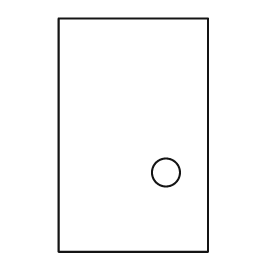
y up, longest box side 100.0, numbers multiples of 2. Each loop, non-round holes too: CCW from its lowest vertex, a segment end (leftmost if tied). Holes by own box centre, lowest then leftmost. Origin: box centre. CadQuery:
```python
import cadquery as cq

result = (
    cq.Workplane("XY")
    .moveTo(-32.0, -50.0)
    .lineTo(32.0, -50.0)
    .lineTo(32.0, 50.0)
    .lineTo(-32.0, 50.0)
    .close()
    .moveTo(14.0, -16.0)
    .circle(6.0)
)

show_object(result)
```